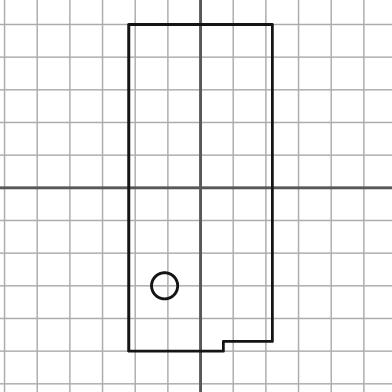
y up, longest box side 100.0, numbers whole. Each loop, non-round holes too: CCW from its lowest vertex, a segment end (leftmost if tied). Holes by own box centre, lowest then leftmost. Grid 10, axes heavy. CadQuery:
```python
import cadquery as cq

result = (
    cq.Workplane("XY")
    .moveTo(-22.0, -50.0)
    .lineTo(7.0, -50.0)
    .lineTo(7.0, -47.0)
    .lineTo(22.0, -47.0)
    .lineTo(22.0, 50.0)
    .lineTo(-22.0, 50.0)
    .close()
    .moveTo(-11.0, -30.0)
    .circle(4.0)
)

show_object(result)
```